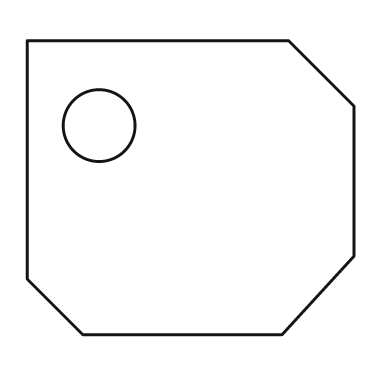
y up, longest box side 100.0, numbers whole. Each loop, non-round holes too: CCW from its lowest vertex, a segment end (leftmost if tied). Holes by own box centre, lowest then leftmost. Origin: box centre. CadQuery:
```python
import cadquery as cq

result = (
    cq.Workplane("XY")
    .moveTo(-33.0, -45.0)
    .lineTo(28.0, -45.0)
    .lineTo(50.0, -21.0)
    .lineTo(50.0, 25.0)
    .lineTo(30.0, 45.0)
    .lineTo(-50.0, 45.0)
    .lineTo(-50.0, -28.0)
    .close()
    .moveTo(-28.0, 19.0)
    .circle(11.0)
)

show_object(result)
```